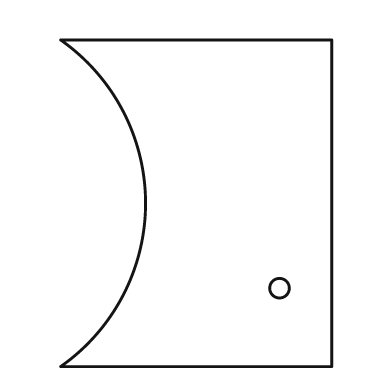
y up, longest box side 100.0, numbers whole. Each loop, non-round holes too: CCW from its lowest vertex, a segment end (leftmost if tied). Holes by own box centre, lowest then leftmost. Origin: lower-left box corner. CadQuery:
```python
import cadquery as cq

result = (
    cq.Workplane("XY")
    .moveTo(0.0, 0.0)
    .lineTo(83.0, 0.0)
    .lineTo(83.0, 100.0)
    .lineTo(0.0, 100.0)
    .threePointArc((26.0, 50.0), (0.0, 0.0))
    .close()
    .moveTo(67.0, 24.0)
    .circle(3.0)
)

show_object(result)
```